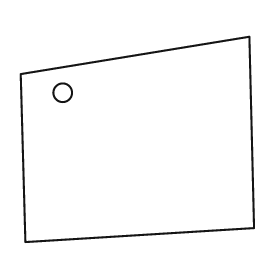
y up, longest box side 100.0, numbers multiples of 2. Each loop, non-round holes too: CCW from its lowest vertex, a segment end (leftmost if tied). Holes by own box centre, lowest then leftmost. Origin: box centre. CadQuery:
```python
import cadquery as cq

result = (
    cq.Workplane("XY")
    .moveTo(-48.0, -44.0)
    .lineTo(50.0, -38.0)
    .lineTo(48.0, 44.0)
    .lineTo(-50.0, 28.0)
    .close()
    .moveTo(-32.0, 20.0)
    .circle(4.0)
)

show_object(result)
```